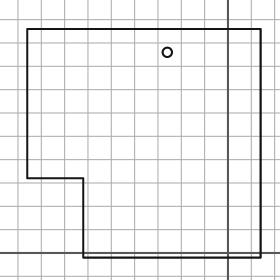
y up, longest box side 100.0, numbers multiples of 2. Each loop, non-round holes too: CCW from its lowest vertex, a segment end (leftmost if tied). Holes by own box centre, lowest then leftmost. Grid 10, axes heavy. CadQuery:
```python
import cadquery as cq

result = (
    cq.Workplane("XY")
    .moveTo(-62.0, -2.0)
    .lineTo(14.0, -2.0)
    .lineTo(14.0, 96.0)
    .lineTo(-86.0, 96.0)
    .lineTo(-86.0, 32.0)
    .lineTo(-62.0, 32.0)
    .close()
    .moveTo(-26.0, 86.0)
    .circle(2.0)
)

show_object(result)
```